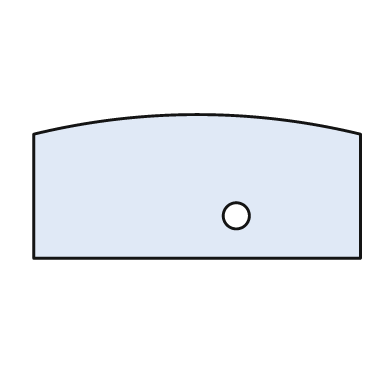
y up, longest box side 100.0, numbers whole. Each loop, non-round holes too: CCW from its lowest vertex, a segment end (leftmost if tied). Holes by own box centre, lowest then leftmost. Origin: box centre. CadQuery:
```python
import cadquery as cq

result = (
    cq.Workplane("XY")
    .moveTo(-50.0, -22.0)
    .lineTo(50.0, -22.0)
    .lineTo(50.0, 16.0)
    .threePointArc((0.0, 22.0), (-50.0, 16.0))
    .close()
    .moveTo(12.0, -9.0)
    .circle(4.0)
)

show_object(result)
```